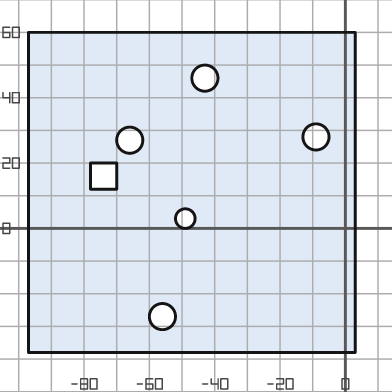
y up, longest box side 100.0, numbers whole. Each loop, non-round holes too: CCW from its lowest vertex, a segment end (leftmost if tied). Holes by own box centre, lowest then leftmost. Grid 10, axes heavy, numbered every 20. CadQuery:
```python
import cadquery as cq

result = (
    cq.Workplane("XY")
    .moveTo(-97.0, -38.0)
    .lineTo(3.0, -38.0)
    .lineTo(3.0, 60.0)
    .lineTo(-97.0, 60.0)
    .close()
    .moveTo(-56.0, -27.0)
    .circle(4.0)
    .moveTo(-49.0, 3.0)
    .circle(3.0)
    .moveTo(-78.0, 12.0)
    .lineTo(-70.0, 12.0)
    .lineTo(-70.0, 20.0)
    .lineTo(-78.0, 20.0)
    .close()
    .moveTo(-66.0, 27.0)
    .circle(4.0)
    .moveTo(-9.0, 28.0)
    .circle(4.0)
    .moveTo(-43.0, 46.0)
    .circle(4.0)
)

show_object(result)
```